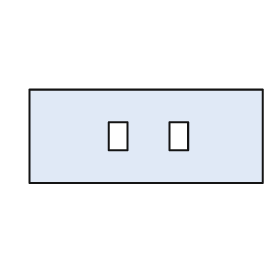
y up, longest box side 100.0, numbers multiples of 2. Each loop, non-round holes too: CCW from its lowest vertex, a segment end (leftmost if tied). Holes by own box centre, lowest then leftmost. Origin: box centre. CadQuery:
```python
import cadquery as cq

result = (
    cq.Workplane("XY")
    .moveTo(-50.0, -20.0)
    .lineTo(50.0, -20.0)
    .lineTo(50.0, 20.0)
    .lineTo(-50.0, 20.0)
    .close()
    .moveTo(-16.0, -6.0)
    .lineTo(-8.0, -6.0)
    .lineTo(-8.0, 6.0)
    .lineTo(-16.0, 6.0)
    .close()
    .moveTo(10.0, -6.0)
    .lineTo(18.0, -6.0)
    .lineTo(18.0, 6.0)
    .lineTo(10.0, 6.0)
    .close()
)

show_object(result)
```